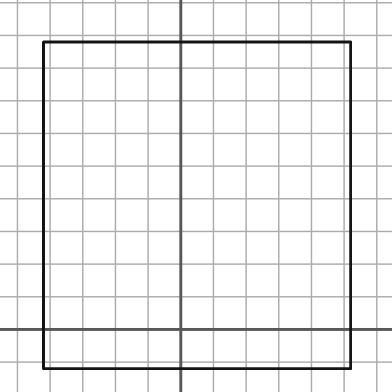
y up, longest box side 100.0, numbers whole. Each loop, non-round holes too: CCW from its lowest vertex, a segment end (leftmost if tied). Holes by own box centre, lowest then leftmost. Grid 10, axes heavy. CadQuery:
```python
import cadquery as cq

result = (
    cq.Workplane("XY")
    .moveTo(-42.0, -12.0)
    .lineTo(52.0, -12.0)
    .lineTo(52.0, 88.0)
    .lineTo(-42.0, 88.0)
    .close()
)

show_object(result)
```